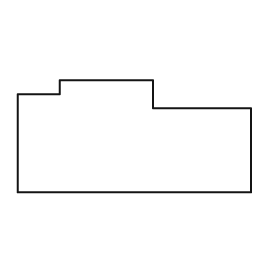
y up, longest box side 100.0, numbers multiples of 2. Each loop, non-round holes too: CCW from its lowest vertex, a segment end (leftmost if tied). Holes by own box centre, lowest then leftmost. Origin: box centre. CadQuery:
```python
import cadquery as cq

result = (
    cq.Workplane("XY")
    .moveTo(-50.0, -24.0)
    .lineTo(50.0, -24.0)
    .lineTo(50.0, 12.0)
    .lineTo(8.0, 12.0)
    .lineTo(8.0, 24.0)
    .lineTo(-32.0, 24.0)
    .lineTo(-32.0, 18.0)
    .lineTo(-50.0, 18.0)
    .close()
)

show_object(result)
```